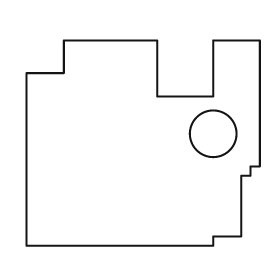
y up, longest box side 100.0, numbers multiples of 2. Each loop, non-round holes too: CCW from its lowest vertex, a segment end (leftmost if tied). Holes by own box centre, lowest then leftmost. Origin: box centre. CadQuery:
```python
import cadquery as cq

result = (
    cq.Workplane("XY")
    .moveTo(-50.0, -44.0)
    .lineTo(30.0, -44.0)
    .lineTo(30.0, -40.0)
    .lineTo(42.0, -40.0)
    .lineTo(42.0, -14.0)
    .lineTo(46.0, -14.0)
    .lineTo(46.0, -10.0)
    .lineTo(50.0, -10.0)
    .lineTo(50.0, 44.0)
    .lineTo(30.0, 44.0)
    .lineTo(30.0, 20.0)
    .lineTo(6.0, 20.0)
    .lineTo(6.0, 44.0)
    .lineTo(-34.0, 44.0)
    .lineTo(-34.0, 30.0)
    .lineTo(-50.0, 30.0)
    .close()
    .moveTo(30.0, 4.0)
    .circle(10.0)
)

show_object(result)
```